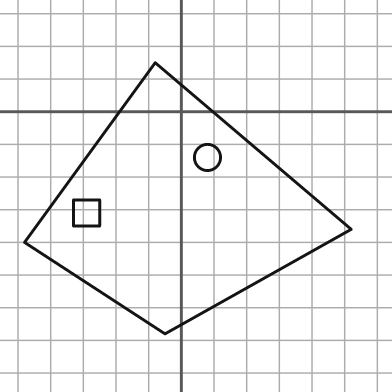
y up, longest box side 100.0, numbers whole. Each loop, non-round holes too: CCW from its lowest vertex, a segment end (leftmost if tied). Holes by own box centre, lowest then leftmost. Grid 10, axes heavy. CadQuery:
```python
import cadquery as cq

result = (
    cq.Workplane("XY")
    .moveTo(-5.0, -68.0)
    .lineTo(52.0, -36.0)
    .lineTo(-8.0, 15.0)
    .lineTo(-48.0, -40.0)
    .close()
    .moveTo(-33.0, -35.0)
    .lineTo(-25.0, -35.0)
    .lineTo(-25.0, -27.0)
    .lineTo(-33.0, -27.0)
    .close()
    .moveTo(8.0, -14.0)
    .circle(4.0)
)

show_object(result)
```